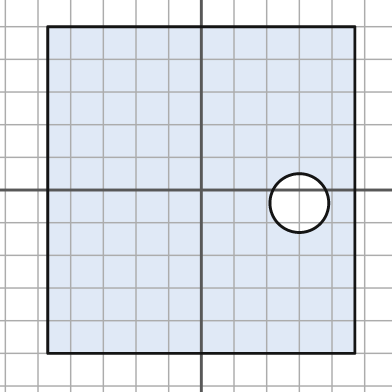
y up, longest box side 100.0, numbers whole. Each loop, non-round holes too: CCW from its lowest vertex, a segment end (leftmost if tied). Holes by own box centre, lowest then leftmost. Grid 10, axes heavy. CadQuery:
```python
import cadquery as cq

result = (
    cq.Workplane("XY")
    .moveTo(-47.0, -50.0)
    .lineTo(47.0, -50.0)
    .lineTo(47.0, 50.0)
    .lineTo(-47.0, 50.0)
    .close()
    .moveTo(30.0, -4.0)
    .circle(9.0)
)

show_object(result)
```